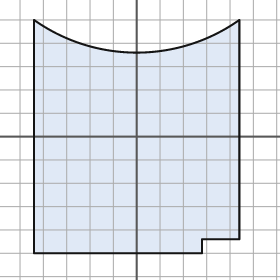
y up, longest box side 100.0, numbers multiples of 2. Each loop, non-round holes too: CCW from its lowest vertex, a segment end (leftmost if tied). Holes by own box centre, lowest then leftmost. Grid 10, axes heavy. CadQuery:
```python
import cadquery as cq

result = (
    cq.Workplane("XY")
    .moveTo(-44.0, -50.0)
    .lineTo(28.0, -50.0)
    .lineTo(28.0, -44.0)
    .lineTo(44.0, -44.0)
    .lineTo(44.0, 50.0)
    .threePointArc((0.0, 36.0), (-44.0, 50.0))
    .close()
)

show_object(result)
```